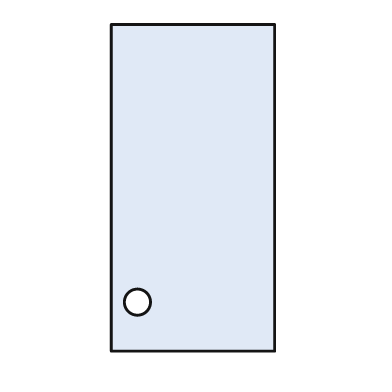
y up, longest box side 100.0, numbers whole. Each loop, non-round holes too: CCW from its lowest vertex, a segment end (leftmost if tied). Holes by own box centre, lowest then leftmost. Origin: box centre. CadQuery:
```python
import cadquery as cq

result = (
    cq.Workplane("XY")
    .moveTo(-25.0, -50.0)
    .lineTo(25.0, -50.0)
    .lineTo(25.0, 50.0)
    .lineTo(-25.0, 50.0)
    .close()
    .moveTo(-17.0, -35.0)
    .circle(4.0)
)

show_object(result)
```